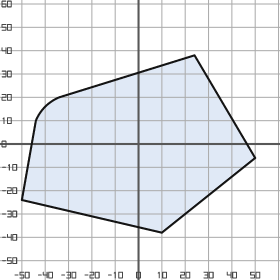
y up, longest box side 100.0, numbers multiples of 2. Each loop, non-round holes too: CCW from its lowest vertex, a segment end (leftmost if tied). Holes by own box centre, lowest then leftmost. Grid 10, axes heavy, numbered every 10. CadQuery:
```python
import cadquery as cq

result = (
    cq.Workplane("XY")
    .moveTo(10.0, -38.0)
    .lineTo(50.0, -6.0)
    .lineTo(24.0, 38.0)
    .lineTo(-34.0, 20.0)
    .threePointArc((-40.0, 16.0), (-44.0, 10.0))
    .lineTo(-50.0, -24.0)
    .close()
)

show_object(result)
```